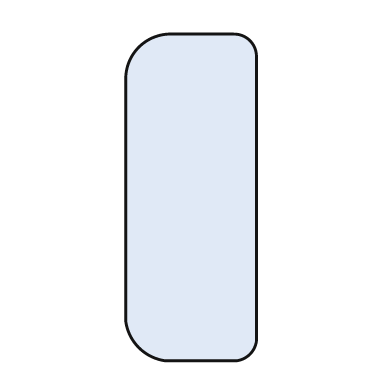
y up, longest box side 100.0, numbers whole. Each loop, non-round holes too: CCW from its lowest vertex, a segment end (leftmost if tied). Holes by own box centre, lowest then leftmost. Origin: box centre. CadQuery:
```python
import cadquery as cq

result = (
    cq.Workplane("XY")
    .moveTo(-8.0, -50.0)
    .lineTo(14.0, -50.0)
    .threePointArc((18.0, -48.0), (20.0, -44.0))
    .lineTo(20.0, 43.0)
    .threePointArc((18.0, 48.0), (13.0, 50.0))
    .lineTo(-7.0, 50.0)
    .threePointArc((-16.0, 46.0), (-20.0, 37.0))
    .lineTo(-20.0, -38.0)
    .threePointArc((-16.0, -46.0), (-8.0, -50.0))
    .close()
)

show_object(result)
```